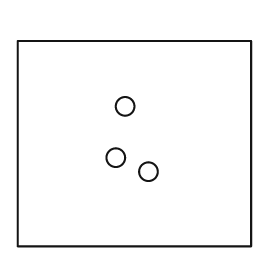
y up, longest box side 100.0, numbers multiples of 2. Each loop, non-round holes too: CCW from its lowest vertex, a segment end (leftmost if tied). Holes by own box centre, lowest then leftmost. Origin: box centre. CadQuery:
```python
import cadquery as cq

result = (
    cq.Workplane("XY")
    .moveTo(-50.0, -44.0)
    .lineTo(50.0, -44.0)
    .lineTo(50.0, 44.0)
    .lineTo(-50.0, 44.0)
    .close()
    .moveTo(6.0, -12.0)
    .circle(4.0)
    .moveTo(-8.0, -6.0)
    .circle(4.0)
    .moveTo(-4.0, 16.0)
    .circle(4.0)
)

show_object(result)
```